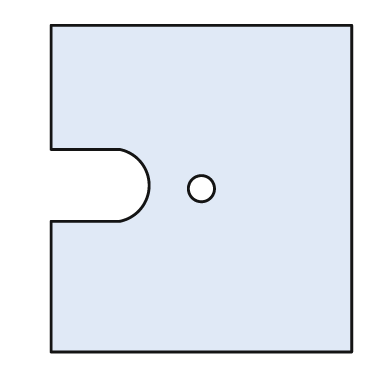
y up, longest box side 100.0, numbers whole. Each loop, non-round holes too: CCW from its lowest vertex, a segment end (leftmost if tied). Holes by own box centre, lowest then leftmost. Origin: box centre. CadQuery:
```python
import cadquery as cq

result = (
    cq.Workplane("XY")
    .moveTo(-46.0, -50.0)
    .lineTo(46.0, -50.0)
    .lineTo(46.0, 50.0)
    .lineTo(-46.0, 50.0)
    .lineTo(-46.0, 12.0)
    .lineTo(-25.0, 12.0)
    .threePointArc((-16.0, 1.0), (-25.0, -10.0))
    .lineTo(-46.0, -10.0)
    .close()
    .moveTo(0.0, 0.0)
    .circle(4.0)
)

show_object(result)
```